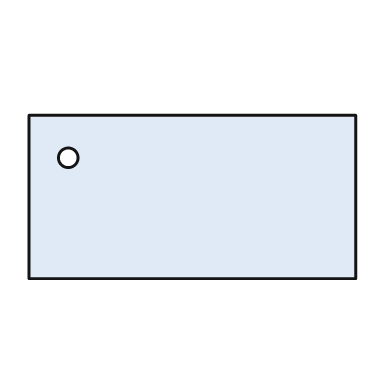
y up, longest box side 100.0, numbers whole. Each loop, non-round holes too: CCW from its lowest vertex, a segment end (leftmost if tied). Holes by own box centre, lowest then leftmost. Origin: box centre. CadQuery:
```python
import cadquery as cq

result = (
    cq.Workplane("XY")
    .moveTo(-50.0, -25.0)
    .lineTo(50.0, -25.0)
    .lineTo(50.0, 25.0)
    .lineTo(-50.0, 25.0)
    .close()
    .moveTo(-38.0, 12.0)
    .circle(3.0)
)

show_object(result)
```